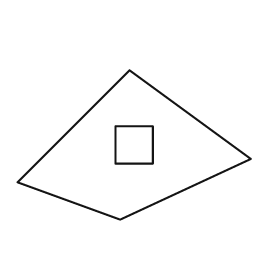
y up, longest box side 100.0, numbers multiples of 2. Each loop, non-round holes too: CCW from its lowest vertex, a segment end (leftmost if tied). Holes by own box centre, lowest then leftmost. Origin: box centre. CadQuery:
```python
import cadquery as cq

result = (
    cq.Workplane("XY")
    .moveTo(-6.0, -32.0)
    .lineTo(50.0, -6.0)
    .lineTo(-2.0, 32.0)
    .lineTo(-50.0, -16.0)
    .close()
    .moveTo(-8.0, -8.0)
    .lineTo(8.0, -8.0)
    .lineTo(8.0, 8.0)
    .lineTo(-8.0, 8.0)
    .close()
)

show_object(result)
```